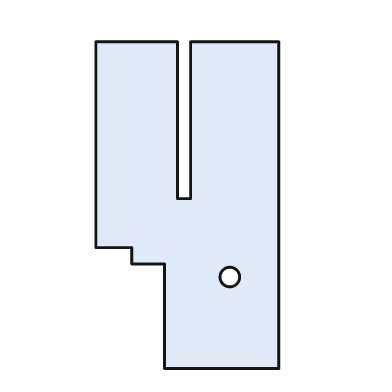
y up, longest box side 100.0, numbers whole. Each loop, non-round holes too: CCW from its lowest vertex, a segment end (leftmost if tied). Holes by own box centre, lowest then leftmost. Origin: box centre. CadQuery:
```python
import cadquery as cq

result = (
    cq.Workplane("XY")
    .moveTo(-7.0, -50.0)
    .lineTo(28.0, -50.0)
    .lineTo(28.0, 50.0)
    .lineTo(1.0, 50.0)
    .lineTo(1.0, 2.0)
    .lineTo(-3.0, 2.0)
    .lineTo(-3.0, 50.0)
    .lineTo(-28.0, 50.0)
    .lineTo(-28.0, -13.0)
    .lineTo(-17.0, -13.0)
    .lineTo(-17.0, -18.0)
    .lineTo(-7.0, -18.0)
    .close()
    .moveTo(13.0, -22.0)
    .circle(3.0)
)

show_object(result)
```